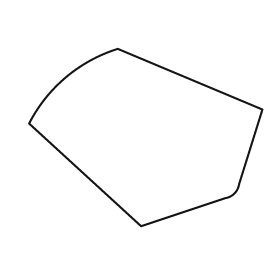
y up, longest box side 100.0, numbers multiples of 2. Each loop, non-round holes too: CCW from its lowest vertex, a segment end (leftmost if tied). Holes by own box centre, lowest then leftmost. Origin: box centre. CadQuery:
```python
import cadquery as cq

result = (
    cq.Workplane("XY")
    .moveTo(-2.0, -38.0)
    .lineTo(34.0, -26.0)
    .threePointArc((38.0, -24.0), (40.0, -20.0))
    .lineTo(50.0, 12.0)
    .lineTo(-12.0, 38.0)
    .threePointArc((-34.0, 26.0), (-50.0, 6.0))
    .close()
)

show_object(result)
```